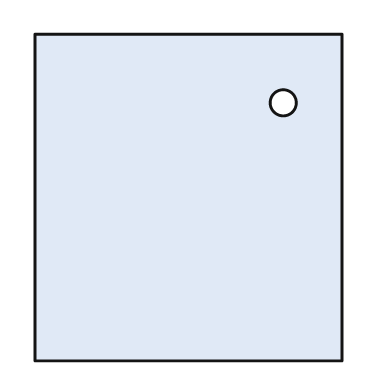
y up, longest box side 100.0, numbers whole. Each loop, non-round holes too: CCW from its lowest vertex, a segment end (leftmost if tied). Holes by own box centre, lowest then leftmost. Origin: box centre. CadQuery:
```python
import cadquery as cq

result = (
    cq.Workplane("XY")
    .moveTo(-47.0, -50.0)
    .lineTo(47.0, -50.0)
    .lineTo(47.0, 50.0)
    .lineTo(-47.0, 50.0)
    .close()
    .moveTo(29.0, 29.0)
    .circle(4.0)
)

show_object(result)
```